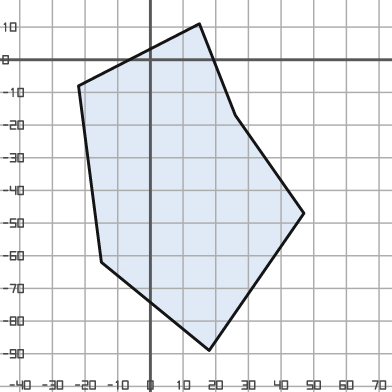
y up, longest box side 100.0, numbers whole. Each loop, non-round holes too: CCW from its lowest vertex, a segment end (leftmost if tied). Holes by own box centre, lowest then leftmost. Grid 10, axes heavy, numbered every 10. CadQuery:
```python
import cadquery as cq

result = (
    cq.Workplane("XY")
    .moveTo(18.0, -89.0)
    .lineTo(47.0, -47.0)
    .lineTo(26.0, -17.0)
    .lineTo(15.0, 11.0)
    .lineTo(-22.0, -8.0)
    .lineTo(-15.0, -62.0)
    .close()
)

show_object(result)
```